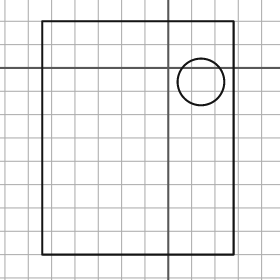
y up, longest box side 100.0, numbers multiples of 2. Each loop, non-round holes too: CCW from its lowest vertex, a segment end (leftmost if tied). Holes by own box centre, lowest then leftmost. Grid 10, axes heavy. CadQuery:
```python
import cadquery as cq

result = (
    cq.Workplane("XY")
    .moveTo(-54.0, -80.0)
    .lineTo(28.0, -80.0)
    .lineTo(28.0, 20.0)
    .lineTo(-54.0, 20.0)
    .close()
    .moveTo(14.0, -6.0)
    .circle(10.0)
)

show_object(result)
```